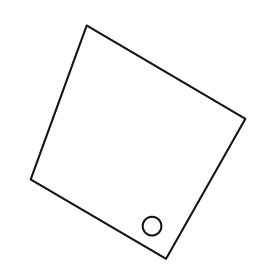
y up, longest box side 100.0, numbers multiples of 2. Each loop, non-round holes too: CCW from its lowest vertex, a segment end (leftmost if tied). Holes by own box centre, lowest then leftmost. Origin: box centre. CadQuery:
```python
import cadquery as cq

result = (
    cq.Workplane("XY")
    .moveTo(12.0, -50.0)
    .lineTo(46.0, 10.0)
    .lineTo(-22.0, 50.0)
    .lineTo(-46.0, -16.0)
    .close()
    .moveTo(6.0, -36.0)
    .circle(4.0)
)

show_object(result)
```